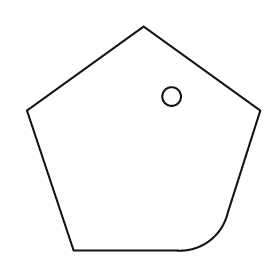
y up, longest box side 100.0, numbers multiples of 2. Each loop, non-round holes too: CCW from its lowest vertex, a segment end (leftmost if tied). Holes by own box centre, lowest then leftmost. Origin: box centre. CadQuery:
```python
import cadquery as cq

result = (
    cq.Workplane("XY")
    .moveTo(-30.0, -48.0)
    .lineTo(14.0, -48.0)
    .threePointArc((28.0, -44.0), (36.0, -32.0))
    .lineTo(50.0, 12.0)
    .lineTo(0.0, 48.0)
    .lineTo(-50.0, 12.0)
    .close()
    .moveTo(12.0, 18.0)
    .circle(4.0)
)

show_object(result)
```